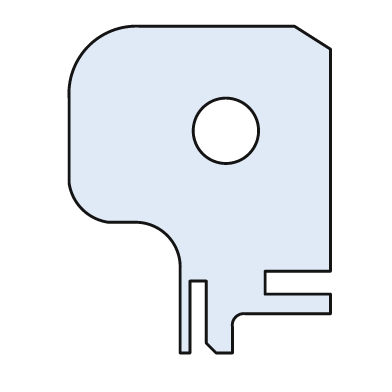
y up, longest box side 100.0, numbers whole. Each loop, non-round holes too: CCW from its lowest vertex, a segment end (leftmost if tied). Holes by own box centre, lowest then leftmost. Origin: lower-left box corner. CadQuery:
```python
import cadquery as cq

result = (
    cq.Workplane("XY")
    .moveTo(34.0, 0.0)
    .lineTo(37.0, 0.0)
    .lineTo(37.0, 22.0)
    .lineTo(42.0, 22.0)
    .lineTo(42.0, 3.0)
    .lineTo(45.0, 0.0)
    .lineTo(50.0, 0.0)
    .lineTo(50.0, 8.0)
    .threePointArc((51.0, 11.0), (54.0, 12.0))
    .lineTo(80.0, 12.0)
    .lineTo(80.0, 18.0)
    .lineTo(60.0, 18.0)
    .lineTo(60.0, 25.0)
    .lineTo(80.0, 25.0)
    .lineTo(80.0, 93.0)
    .lineTo(69.0, 100.0)
    .lineTo(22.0, 100.0)
    .threePointArc((6.0, 94.0), (0.0, 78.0))
    .lineTo(0.0, 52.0)
    .threePointArc((4.0, 44.0), (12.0, 40.0))
    .lineTo(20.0, 40.0)
    .threePointArc((30.0, 36.0), (34.0, 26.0))
    .close()
    .moveTo(48.0, 68.0)
    .circle(10.0)
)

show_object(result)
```